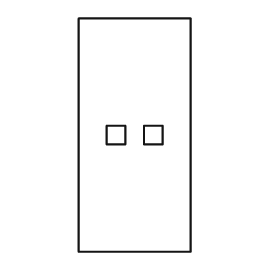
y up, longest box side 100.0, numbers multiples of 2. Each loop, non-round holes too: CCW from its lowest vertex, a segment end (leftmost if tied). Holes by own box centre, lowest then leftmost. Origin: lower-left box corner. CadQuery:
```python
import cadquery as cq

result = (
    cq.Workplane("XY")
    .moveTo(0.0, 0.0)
    .lineTo(48.0, 0.0)
    .lineTo(48.0, 100.0)
    .lineTo(0.0, 100.0)
    .close()
    .moveTo(12.0, 46.0)
    .lineTo(20.0, 46.0)
    .lineTo(20.0, 54.0)
    .lineTo(12.0, 54.0)
    .close()
    .moveTo(28.0, 46.0)
    .lineTo(36.0, 46.0)
    .lineTo(36.0, 54.0)
    .lineTo(28.0, 54.0)
    .close()
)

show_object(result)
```